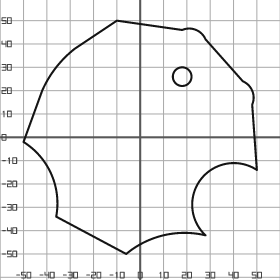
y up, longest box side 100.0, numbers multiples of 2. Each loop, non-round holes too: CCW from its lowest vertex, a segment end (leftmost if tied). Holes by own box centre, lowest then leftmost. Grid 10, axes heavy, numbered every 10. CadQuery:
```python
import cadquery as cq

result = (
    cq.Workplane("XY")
    .moveTo(-6.0, -50.0)
    .threePointArc((10.0, -42.0), (28.0, -42.0))
    .threePointArc((26.0, -18.0), (50.0, -14.0))
    .lineTo(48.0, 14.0)
    .threePointArc((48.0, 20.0), (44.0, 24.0))
    .lineTo(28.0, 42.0)
    .threePointArc((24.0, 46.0), (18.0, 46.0))
    .lineTo(-10.0, 50.0)
    .lineTo(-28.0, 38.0)
    .threePointArc((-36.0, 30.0), (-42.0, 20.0))
    .lineTo(-50.0, -2.0)
    .threePointArc((-38.0, -16.0), (-36.0, -34.0))
    .close()
    .moveTo(18.0, 26.0)
    .circle(4.0)
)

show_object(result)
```